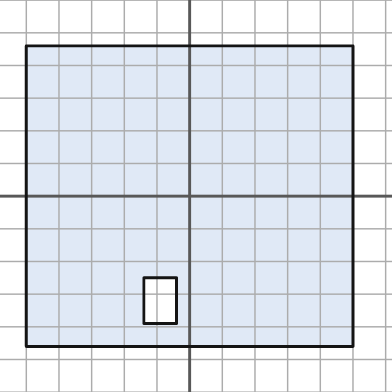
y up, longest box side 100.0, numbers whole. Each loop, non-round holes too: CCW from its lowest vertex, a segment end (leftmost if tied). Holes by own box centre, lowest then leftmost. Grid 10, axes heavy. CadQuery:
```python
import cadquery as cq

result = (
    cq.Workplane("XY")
    .moveTo(-50.0, -46.0)
    .lineTo(50.0, -46.0)
    .lineTo(50.0, 46.0)
    .lineTo(-50.0, 46.0)
    .close()
    .moveTo(-14.0, -39.0)
    .lineTo(-4.0, -39.0)
    .lineTo(-4.0, -25.0)
    .lineTo(-14.0, -25.0)
    .close()
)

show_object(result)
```